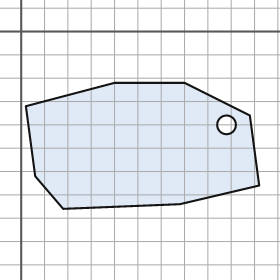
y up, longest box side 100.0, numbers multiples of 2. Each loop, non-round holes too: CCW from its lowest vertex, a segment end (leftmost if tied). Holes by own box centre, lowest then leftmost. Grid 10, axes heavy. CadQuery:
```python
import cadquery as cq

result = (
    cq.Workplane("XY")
    .moveTo(18.0, -76.0)
    .lineTo(68.0, -74.0)
    .lineTo(102.0, -66.0)
    .lineTo(98.0, -36.0)
    .lineTo(70.0, -22.0)
    .lineTo(40.0, -22.0)
    .lineTo(2.0, -32.0)
    .lineTo(6.0, -62.0)
    .close()
    .moveTo(88.0, -40.0)
    .circle(4.0)
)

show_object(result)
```